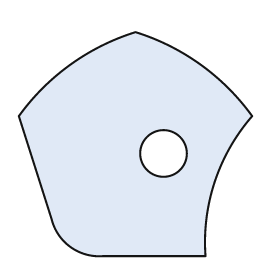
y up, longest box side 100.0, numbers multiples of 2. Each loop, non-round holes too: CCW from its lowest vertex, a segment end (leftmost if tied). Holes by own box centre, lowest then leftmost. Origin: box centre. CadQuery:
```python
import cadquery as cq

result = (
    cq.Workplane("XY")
    .moveTo(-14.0, -48.0)
    .lineTo(30.0, -48.0)
    .threePointArc((34.0, -16.0), (50.0, 12.0))
    .threePointArc((28.0, 34.0), (0.0, 48.0))
    .threePointArc((-28.0, 34.0), (-50.0, 12.0))
    .lineTo(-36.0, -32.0)
    .threePointArc((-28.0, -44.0), (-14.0, -48.0))
    .close()
    .moveTo(12.0, -4.0)
    .circle(10.0)
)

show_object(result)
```